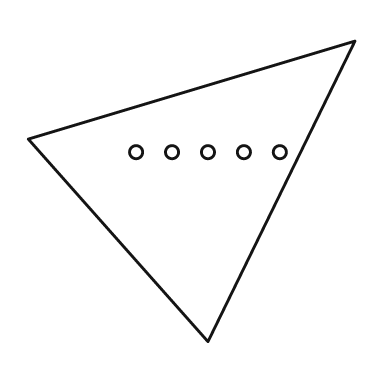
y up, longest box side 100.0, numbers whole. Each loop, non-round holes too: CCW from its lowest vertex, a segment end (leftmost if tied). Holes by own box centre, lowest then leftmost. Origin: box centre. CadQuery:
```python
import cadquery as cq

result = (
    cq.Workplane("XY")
    .moveTo(5.0, -46.0)
    .lineTo(50.0, 46.0)
    .lineTo(-50.0, 16.0)
    .close()
    .moveTo(-17.0, 12.0)
    .circle(2.0)
    .moveTo(-6.0, 12.0)
    .circle(2.0)
    .moveTo(5.0, 12.0)
    .circle(2.0)
    .moveTo(16.0, 12.0)
    .circle(2.0)
    .moveTo(27.0, 12.0)
    .circle(2.0)
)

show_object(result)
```